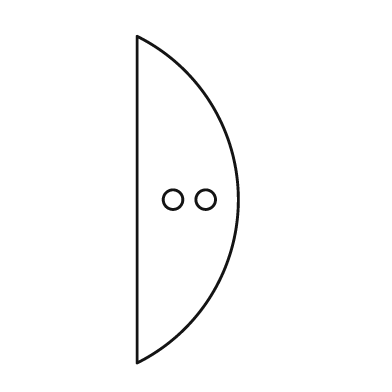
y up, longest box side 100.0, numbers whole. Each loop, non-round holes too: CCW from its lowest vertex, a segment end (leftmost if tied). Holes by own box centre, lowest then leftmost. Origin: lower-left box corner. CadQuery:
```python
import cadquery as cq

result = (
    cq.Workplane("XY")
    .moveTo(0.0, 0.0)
    .threePointArc((31.0, 50.0), (0.0, 100.0))
    .close()
    .moveTo(11.0, 50.0)
    .circle(3.0)
    .moveTo(21.0, 50.0)
    .circle(3.0)
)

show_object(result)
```